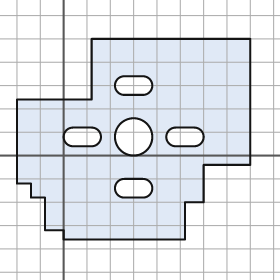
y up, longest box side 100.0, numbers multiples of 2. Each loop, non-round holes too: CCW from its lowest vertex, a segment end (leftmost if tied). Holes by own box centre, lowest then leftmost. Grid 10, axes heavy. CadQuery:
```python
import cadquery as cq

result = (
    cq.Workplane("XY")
    .moveTo(0.0, -36.0)
    .lineTo(52.0, -36.0)
    .lineTo(52.0, -20.0)
    .lineTo(60.0, -20.0)
    .lineTo(60.0, -4.0)
    .lineTo(80.0, -4.0)
    .lineTo(80.0, 50.0)
    .lineTo(12.0, 50.0)
    .lineTo(12.0, 24.0)
    .lineTo(-20.0, 24.0)
    .lineTo(-20.0, -12.0)
    .lineTo(-14.0, -12.0)
    .lineTo(-14.0, -18.0)
    .lineTo(-8.0, -18.0)
    .lineTo(-8.0, -32.0)
    .lineTo(0.0, -32.0)
    .close()
    .moveTo(26.0, -18.0)
    .lineTo(34.0, -18.0)
    .threePointArc((38.0, -14.0), (34.0, -10.0))
    .lineTo(26.0, -10.0)
    .threePointArc((22.0, -14.0), (26.0, -18.0))
    .close()
    .moveTo(4.0, 4.0)
    .lineTo(12.0, 4.0)
    .threePointArc((16.0, 8.0), (12.0, 12.0))
    .lineTo(4.0, 12.0)
    .threePointArc((0.0, 8.0), (4.0, 4.0))
    .close()
    .moveTo(30.0, 8.0)
    .circle(8.0)
    .moveTo(48.0, 4.0)
    .lineTo(56.0, 4.0)
    .threePointArc((60.0, 8.0), (56.0, 12.0))
    .lineTo(48.0, 12.0)
    .threePointArc((44.0, 8.0), (48.0, 4.0))
    .close()
    .moveTo(26.0, 26.0)
    .lineTo(34.0, 26.0)
    .threePointArc((38.0, 30.0), (34.0, 34.0))
    .lineTo(26.0, 34.0)
    .threePointArc((22.0, 30.0), (26.0, 26.0))
    .close()
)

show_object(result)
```